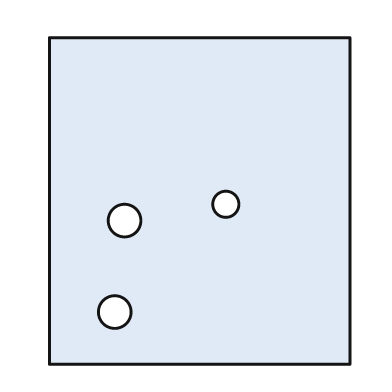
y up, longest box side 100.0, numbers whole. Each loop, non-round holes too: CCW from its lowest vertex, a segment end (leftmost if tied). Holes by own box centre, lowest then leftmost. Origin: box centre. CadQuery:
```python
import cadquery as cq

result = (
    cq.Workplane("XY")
    .moveTo(-46.0, -50.0)
    .lineTo(46.0, -50.0)
    .lineTo(46.0, 50.0)
    .lineTo(-46.0, 50.0)
    .close()
    .moveTo(-26.0, -34.0)
    .circle(5.0)
    .moveTo(-23.0, -6.0)
    .circle(5.0)
    .moveTo(8.0, -1.0)
    .circle(4.0)
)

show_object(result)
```